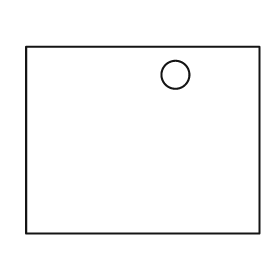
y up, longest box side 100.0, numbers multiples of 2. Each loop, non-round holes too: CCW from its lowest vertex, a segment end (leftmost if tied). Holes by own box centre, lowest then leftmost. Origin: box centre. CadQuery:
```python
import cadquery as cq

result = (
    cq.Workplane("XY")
    .moveTo(-50.0, -40.0)
    .lineTo(50.0, -40.0)
    .lineTo(50.0, 40.0)
    .lineTo(-50.0, 40.0)
    .close()
    .moveTo(14.0, 28.0)
    .circle(6.0)
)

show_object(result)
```